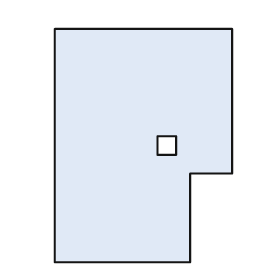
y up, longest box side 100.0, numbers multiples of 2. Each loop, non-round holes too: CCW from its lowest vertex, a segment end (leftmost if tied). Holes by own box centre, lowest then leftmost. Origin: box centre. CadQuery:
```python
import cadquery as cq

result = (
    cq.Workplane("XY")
    .moveTo(-38.0, -50.0)
    .lineTo(20.0, -50.0)
    .lineTo(20.0, -12.0)
    .lineTo(38.0, -12.0)
    .lineTo(38.0, 50.0)
    .lineTo(-38.0, 50.0)
    .close()
    .moveTo(6.0, -4.0)
    .lineTo(14.0, -4.0)
    .lineTo(14.0, 4.0)
    .lineTo(6.0, 4.0)
    .close()
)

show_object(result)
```